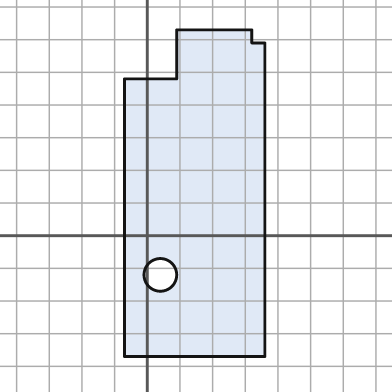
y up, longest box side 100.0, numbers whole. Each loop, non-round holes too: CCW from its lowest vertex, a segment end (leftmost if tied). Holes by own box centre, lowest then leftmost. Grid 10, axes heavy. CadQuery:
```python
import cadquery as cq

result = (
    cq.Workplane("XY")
    .moveTo(-7.0, -37.0)
    .lineTo(36.0, -37.0)
    .lineTo(36.0, 59.0)
    .lineTo(32.0, 59.0)
    .lineTo(32.0, 63.0)
    .lineTo(9.0, 63.0)
    .lineTo(9.0, 48.0)
    .lineTo(-7.0, 48.0)
    .close()
    .moveTo(4.0, -12.0)
    .circle(5.0)
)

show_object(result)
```